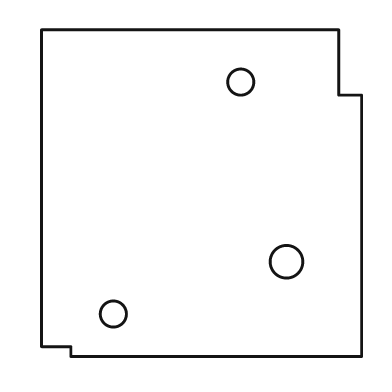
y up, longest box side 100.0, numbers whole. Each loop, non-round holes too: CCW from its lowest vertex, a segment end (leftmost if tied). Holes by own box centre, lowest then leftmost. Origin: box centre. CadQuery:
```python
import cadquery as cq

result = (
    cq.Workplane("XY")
    .moveTo(-40.0, -50.0)
    .lineTo(49.0, -50.0)
    .lineTo(49.0, 30.0)
    .lineTo(42.0, 30.0)
    .lineTo(42.0, 50.0)
    .lineTo(-49.0, 50.0)
    .lineTo(-49.0, -47.0)
    .lineTo(-40.0, -47.0)
    .close()
    .moveTo(-27.0, -37.0)
    .circle(4.0)
    .moveTo(26.0, -21.0)
    .circle(5.0)
    .moveTo(12.0, 34.0)
    .circle(4.0)
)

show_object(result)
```